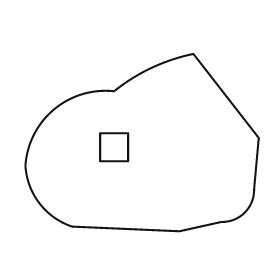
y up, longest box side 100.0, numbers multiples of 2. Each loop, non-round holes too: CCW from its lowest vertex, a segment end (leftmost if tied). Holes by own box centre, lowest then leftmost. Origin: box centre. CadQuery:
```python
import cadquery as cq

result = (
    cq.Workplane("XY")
    .moveTo(16.0, -38.0)
    .lineTo(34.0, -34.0)
    .threePointArc((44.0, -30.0), (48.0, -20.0))
    .lineTo(50.0, 2.0)
    .lineTo(22.0, 38.0)
    .threePointArc((4.0, 32.0), (-12.0, 22.0))
    .threePointArc((-38.0, 14.0), (-50.0, -10.0))
    .threePointArc((-44.0, -26.0), (-30.0, -36.0))
    .close()
    .moveTo(-18.0, -8.0)
    .lineTo(-6.0, -8.0)
    .lineTo(-6.0, 4.0)
    .lineTo(-18.0, 4.0)
    .close()
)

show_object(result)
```